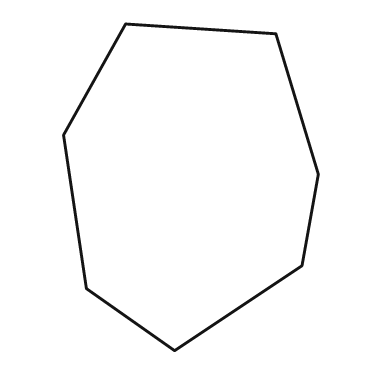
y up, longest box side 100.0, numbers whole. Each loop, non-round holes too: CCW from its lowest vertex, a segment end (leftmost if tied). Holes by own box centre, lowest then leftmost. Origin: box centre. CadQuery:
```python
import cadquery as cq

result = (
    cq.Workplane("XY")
    .moveTo(-5.0, -50.0)
    .lineTo(34.0, -24.0)
    .lineTo(39.0, 4.0)
    .lineTo(26.0, 47.0)
    .lineTo(-20.0, 50.0)
    .lineTo(-39.0, 16.0)
    .lineTo(-32.0, -31.0)
    .close()
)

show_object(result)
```